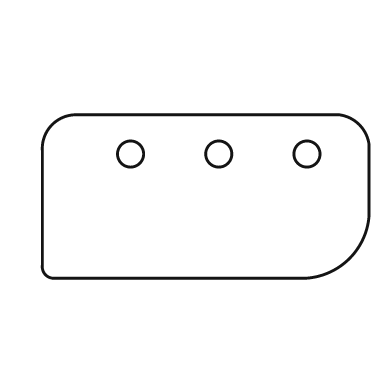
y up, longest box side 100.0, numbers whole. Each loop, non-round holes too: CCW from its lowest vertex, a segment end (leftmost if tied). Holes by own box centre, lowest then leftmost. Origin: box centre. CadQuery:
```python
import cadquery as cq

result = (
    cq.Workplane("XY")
    .moveTo(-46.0, -25.0)
    .lineTo(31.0, -25.0)
    .threePointArc((44.0, -19.0), (50.0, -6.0))
    .lineTo(50.0, 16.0)
    .threePointArc((47.0, 22.0), (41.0, 25.0))
    .lineTo(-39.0, 25.0)
    .threePointArc((-47.0, 22.0), (-50.0, 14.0))
    .lineTo(-50.0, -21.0)
    .threePointArc((-49.0, -24.0), (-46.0, -25.0))
    .close()
    .moveTo(-23.0, 13.0)
    .circle(4.0)
    .moveTo(4.0, 13.0)
    .circle(4.0)
    .moveTo(31.0, 13.0)
    .circle(4.0)
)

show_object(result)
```